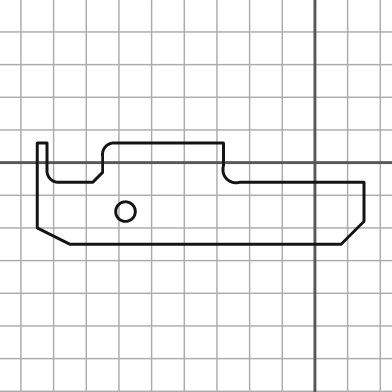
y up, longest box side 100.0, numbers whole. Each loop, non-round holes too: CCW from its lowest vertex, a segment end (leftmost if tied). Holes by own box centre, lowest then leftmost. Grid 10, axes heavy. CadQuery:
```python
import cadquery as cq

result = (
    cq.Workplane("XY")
    .moveTo(-75.0, -25.0)
    .lineTo(8.0, -25.0)
    .lineTo(15.0, -18.0)
    .lineTo(15.0, -6.0)
    .lineTo(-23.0, -6.0)
    .threePointArc((-27.0, -5.0), (-28.0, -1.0))
    .lineTo(-28.0, 6.0)
    .lineTo(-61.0, 6.0)
    .threePointArc((-64.0, 5.0), (-65.0, 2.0))
    .lineTo(-65.0, -3.0)
    .lineTo(-68.0, -6.0)
    .lineTo(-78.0, -6.0)
    .threePointArc((-81.0, -5.0), (-82.0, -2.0))
    .lineTo(-82.0, 6.0)
    .lineTo(-85.0, 6.0)
    .lineTo(-85.0, -20.0)
    .close()
    .moveTo(-58.0, -15.0)
    .circle(3.0)
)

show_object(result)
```